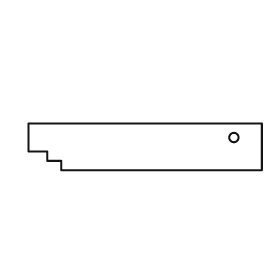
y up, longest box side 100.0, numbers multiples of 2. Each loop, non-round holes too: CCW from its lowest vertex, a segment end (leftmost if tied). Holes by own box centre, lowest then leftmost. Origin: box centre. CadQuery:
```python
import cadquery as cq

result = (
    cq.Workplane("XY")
    .moveTo(-36.0, -10.0)
    .lineTo(50.0, -10.0)
    .lineTo(50.0, 10.0)
    .lineTo(-50.0, 10.0)
    .lineTo(-50.0, -2.0)
    .lineTo(-42.0, -2.0)
    .lineTo(-42.0, -6.0)
    .lineTo(-36.0, -6.0)
    .close()
    .moveTo(38.0, 4.0)
    .circle(2.0)
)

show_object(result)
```